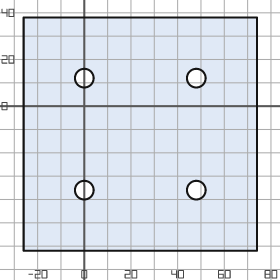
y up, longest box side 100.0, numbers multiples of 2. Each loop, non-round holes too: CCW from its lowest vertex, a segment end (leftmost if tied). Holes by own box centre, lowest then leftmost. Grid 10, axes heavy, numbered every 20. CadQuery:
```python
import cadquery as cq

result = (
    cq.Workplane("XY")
    .moveTo(-26.0, -62.0)
    .lineTo(74.0, -62.0)
    .lineTo(74.0, 38.0)
    .lineTo(-26.0, 38.0)
    .close()
    .moveTo(0.0, -36.0)
    .circle(4.0)
    .moveTo(48.0, -36.0)
    .circle(4.0)
    .moveTo(0.0, 12.0)
    .circle(4.0)
    .moveTo(48.0, 12.0)
    .circle(4.0)
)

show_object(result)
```